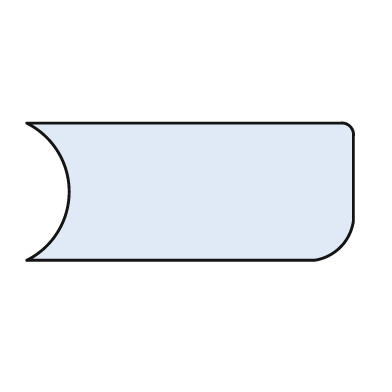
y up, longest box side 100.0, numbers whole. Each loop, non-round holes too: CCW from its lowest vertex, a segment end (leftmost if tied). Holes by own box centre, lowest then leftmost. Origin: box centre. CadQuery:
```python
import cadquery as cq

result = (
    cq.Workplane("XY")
    .moveTo(-50.0, -21.0)
    .lineTo(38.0, -21.0)
    .threePointArc((46.0, -17.0), (50.0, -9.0))
    .lineTo(50.0, 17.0)
    .threePointArc((49.0, 20.0), (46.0, 21.0))
    .lineTo(-50.0, 21.0)
    .threePointArc((-37.0, 0.0), (-50.0, -21.0))
    .close()
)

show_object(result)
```